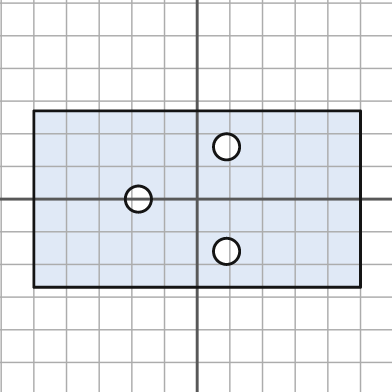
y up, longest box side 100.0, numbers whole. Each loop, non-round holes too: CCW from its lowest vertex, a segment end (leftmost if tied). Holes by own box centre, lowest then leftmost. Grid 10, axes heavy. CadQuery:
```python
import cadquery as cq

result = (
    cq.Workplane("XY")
    .moveTo(-50.0, -27.0)
    .lineTo(50.0, -27.0)
    .lineTo(50.0, 27.0)
    .lineTo(-50.0, 27.0)
    .close()
    .moveTo(9.0, -16.0)
    .circle(4.0)
    .moveTo(-18.0, 0.0)
    .circle(4.0)
    .moveTo(9.0, 16.0)
    .circle(4.0)
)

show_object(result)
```